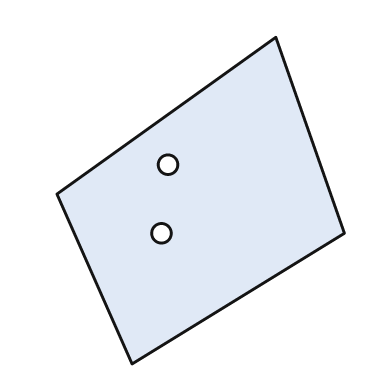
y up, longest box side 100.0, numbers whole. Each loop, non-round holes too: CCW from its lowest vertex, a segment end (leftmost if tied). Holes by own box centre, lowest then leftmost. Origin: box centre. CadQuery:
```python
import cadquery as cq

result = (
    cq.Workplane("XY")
    .moveTo(-21.0, -50.0)
    .lineTo(44.0, -10.0)
    .lineTo(23.0, 50.0)
    .lineTo(-44.0, 2.0)
    .close()
    .moveTo(-12.0, -10.0)
    .circle(3.0)
    .moveTo(-10.0, 11.0)
    .circle(3.0)
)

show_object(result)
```